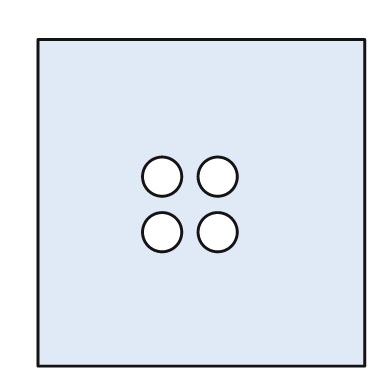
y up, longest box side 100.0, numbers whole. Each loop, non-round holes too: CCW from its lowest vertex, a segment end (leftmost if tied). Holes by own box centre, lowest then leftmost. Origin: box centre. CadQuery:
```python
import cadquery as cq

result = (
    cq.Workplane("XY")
    .moveTo(-50.0, -50.0)
    .lineTo(50.0, -50.0)
    .lineTo(50.0, 50.0)
    .lineTo(-50.0, 50.0)
    .close()
    .moveTo(-12.0, -9.0)
    .circle(6.0)
    .moveTo(5.0, -9.0)
    .circle(6.0)
    .moveTo(-12.0, 8.0)
    .circle(6.0)
    .moveTo(5.0, 8.0)
    .circle(6.0)
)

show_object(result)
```